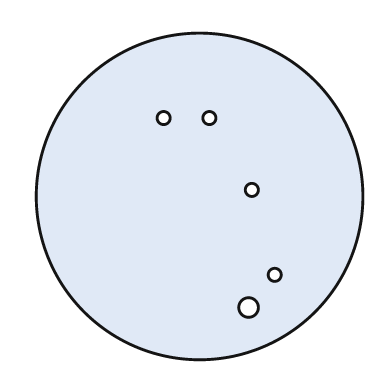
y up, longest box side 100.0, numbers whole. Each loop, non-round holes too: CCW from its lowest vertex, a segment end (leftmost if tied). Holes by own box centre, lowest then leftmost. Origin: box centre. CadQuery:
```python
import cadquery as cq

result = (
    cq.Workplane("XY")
    .moveTo(0.0, 0.0)
    .circle(50.0)
    .moveTo(15.0, -34.0)
    .circle(3.0)
    .moveTo(23.0, -24.0)
    .circle(2.0)
    .moveTo(16.0, 2.0)
    .circle(2.0)
    .moveTo(-11.0, 24.0)
    .circle(2.0)
    .moveTo(3.0, 24.0)
    .circle(2.0)
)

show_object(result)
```